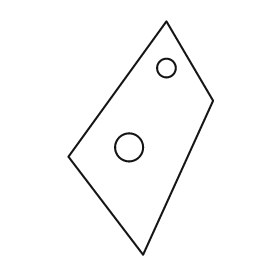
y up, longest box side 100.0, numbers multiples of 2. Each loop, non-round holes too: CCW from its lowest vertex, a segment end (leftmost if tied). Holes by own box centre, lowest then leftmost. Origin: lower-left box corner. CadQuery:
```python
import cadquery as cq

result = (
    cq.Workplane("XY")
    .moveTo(32.0, 0.0)
    .lineTo(62.0, 66.0)
    .lineTo(42.0, 100.0)
    .lineTo(0.0, 42.0)
    .close()
    .moveTo(26.0, 46.0)
    .circle(6.0)
    .moveTo(42.0, 80.0)
    .circle(4.0)
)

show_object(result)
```